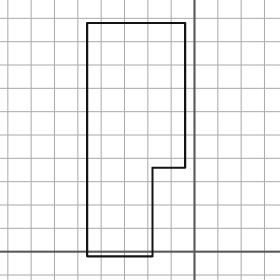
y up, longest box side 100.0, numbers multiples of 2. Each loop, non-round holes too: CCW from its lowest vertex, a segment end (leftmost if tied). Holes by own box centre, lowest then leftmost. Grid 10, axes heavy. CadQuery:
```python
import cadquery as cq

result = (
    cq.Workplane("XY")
    .moveTo(-46.0, -2.0)
    .lineTo(-18.0, -2.0)
    .lineTo(-18.0, 36.0)
    .lineTo(-4.0, 36.0)
    .lineTo(-4.0, 98.0)
    .lineTo(-46.0, 98.0)
    .close()
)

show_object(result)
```